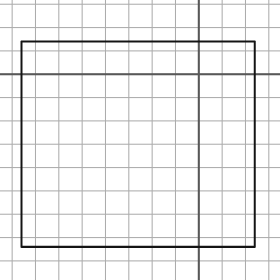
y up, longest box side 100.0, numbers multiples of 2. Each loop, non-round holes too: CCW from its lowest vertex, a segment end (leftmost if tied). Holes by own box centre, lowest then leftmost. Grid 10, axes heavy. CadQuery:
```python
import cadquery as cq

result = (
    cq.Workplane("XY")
    .moveTo(-76.0, -74.0)
    .lineTo(24.0, -74.0)
    .lineTo(24.0, 14.0)
    .lineTo(-76.0, 14.0)
    .close()
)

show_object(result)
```